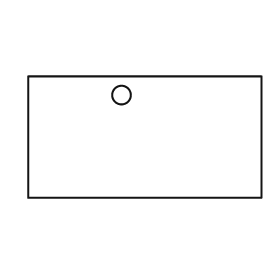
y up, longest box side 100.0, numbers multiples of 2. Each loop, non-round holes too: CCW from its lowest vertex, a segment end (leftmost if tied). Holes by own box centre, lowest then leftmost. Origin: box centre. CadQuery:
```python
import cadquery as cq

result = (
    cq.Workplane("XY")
    .moveTo(-50.0, -26.0)
    .lineTo(50.0, -26.0)
    .lineTo(50.0, 26.0)
    .lineTo(-50.0, 26.0)
    .close()
    .moveTo(-10.0, 18.0)
    .circle(4.0)
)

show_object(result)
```